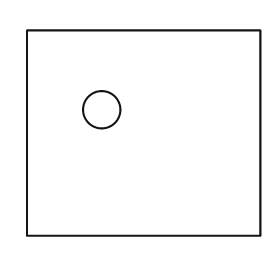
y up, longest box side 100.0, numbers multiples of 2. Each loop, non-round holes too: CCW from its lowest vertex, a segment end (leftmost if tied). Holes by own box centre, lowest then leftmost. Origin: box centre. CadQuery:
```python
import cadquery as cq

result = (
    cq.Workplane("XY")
    .moveTo(-50.0, -44.0)
    .lineTo(50.0, -44.0)
    .lineTo(50.0, 44.0)
    .lineTo(-50.0, 44.0)
    .close()
    .moveTo(-18.0, 10.0)
    .circle(8.0)
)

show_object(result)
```